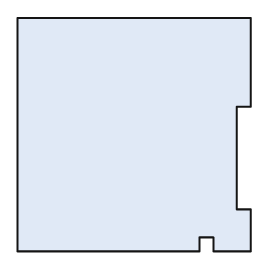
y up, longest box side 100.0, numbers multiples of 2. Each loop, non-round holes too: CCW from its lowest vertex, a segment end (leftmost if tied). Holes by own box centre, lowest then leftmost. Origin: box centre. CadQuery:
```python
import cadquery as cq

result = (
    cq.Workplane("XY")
    .moveTo(-50.0, -50.0)
    .lineTo(28.0, -50.0)
    .lineTo(28.0, -44.0)
    .lineTo(34.0, -44.0)
    .lineTo(34.0, -50.0)
    .lineTo(50.0, -50.0)
    .lineTo(50.0, -32.0)
    .lineTo(44.0, -32.0)
    .lineTo(44.0, 12.0)
    .lineTo(50.0, 12.0)
    .lineTo(50.0, 50.0)
    .lineTo(-50.0, 50.0)
    .close()
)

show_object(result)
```